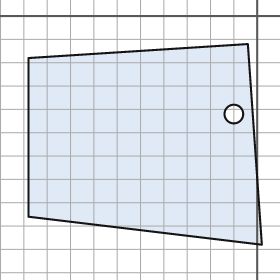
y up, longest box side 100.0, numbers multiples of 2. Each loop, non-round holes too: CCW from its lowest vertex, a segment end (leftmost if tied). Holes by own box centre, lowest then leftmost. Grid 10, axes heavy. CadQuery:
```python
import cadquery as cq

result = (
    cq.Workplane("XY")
    .moveTo(2.0, -98.0)
    .lineTo(-4.0, -12.0)
    .lineTo(-98.0, -18.0)
    .lineTo(-98.0, -86.0)
    .close()
    .moveTo(-10.0, -42.0)
    .circle(4.0)
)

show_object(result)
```